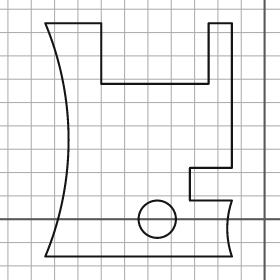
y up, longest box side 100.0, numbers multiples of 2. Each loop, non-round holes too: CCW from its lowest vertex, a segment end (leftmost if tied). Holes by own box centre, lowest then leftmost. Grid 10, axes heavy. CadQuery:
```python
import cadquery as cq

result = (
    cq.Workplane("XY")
    .moveTo(-94.0, -16.0)
    .lineTo(-14.0, -16.0)
    .threePointArc((-16.0, -4.0), (-14.0, 8.0))
    .lineTo(-32.0, 8.0)
    .lineTo(-32.0, 22.0)
    .lineTo(-14.0, 22.0)
    .lineTo(-14.0, 84.0)
    .lineTo(-24.0, 84.0)
    .lineTo(-24.0, 58.0)
    .lineTo(-70.0, 58.0)
    .lineTo(-70.0, 84.0)
    .lineTo(-94.0, 84.0)
    .threePointArc((-84.0, 34.0), (-94.0, -16.0))
    .close()
    .moveTo(-46.0, 0.0)
    .circle(8.0)
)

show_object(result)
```